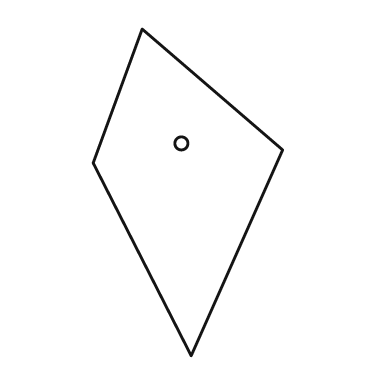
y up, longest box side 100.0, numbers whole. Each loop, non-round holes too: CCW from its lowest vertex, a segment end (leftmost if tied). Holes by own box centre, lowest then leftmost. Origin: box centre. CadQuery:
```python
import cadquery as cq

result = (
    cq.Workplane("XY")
    .moveTo(1.0, -50.0)
    .lineTo(29.0, 13.0)
    .lineTo(-14.0, 50.0)
    .lineTo(-29.0, 9.0)
    .close()
    .moveTo(-2.0, 15.0)
    .circle(2.0)
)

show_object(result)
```